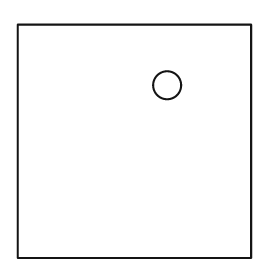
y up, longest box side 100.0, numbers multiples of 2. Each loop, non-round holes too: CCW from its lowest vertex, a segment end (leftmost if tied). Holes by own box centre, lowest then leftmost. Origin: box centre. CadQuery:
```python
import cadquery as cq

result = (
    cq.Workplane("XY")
    .moveTo(-50.0, -50.0)
    .lineTo(50.0, -50.0)
    .lineTo(50.0, 50.0)
    .lineTo(-50.0, 50.0)
    .close()
    .moveTo(14.0, 24.0)
    .circle(6.0)
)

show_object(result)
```